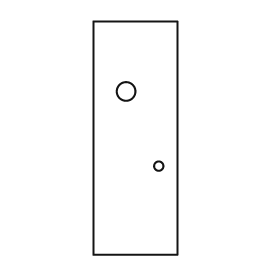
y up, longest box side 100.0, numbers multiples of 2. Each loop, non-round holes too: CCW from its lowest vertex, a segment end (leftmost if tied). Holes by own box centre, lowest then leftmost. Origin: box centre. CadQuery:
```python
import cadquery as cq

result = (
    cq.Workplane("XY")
    .moveTo(-18.0, -50.0)
    .lineTo(18.0, -50.0)
    .lineTo(18.0, 50.0)
    .lineTo(-18.0, 50.0)
    .close()
    .moveTo(10.0, -12.0)
    .circle(2.0)
    .moveTo(-4.0, 20.0)
    .circle(4.0)
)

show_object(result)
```